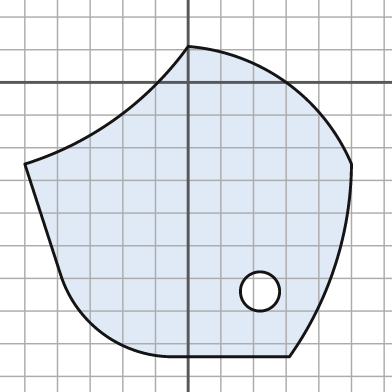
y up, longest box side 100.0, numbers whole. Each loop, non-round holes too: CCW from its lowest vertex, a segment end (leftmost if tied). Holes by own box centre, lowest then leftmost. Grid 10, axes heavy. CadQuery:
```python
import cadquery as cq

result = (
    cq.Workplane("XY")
    .moveTo(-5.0, -84.0)
    .lineTo(31.0, -84.0)
    .threePointArc((45.0, -56.0), (50.0, -25.0))
    .threePointArc((30.0, 0.0), (0.0, 11.0))
    .threePointArc((-22.0, -11.0), (-50.0, -25.0))
    .lineTo(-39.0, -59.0)
    .threePointArc((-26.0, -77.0), (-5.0, -84.0))
    .close()
    .moveTo(22.0, -64.0)
    .circle(6.0)
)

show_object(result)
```